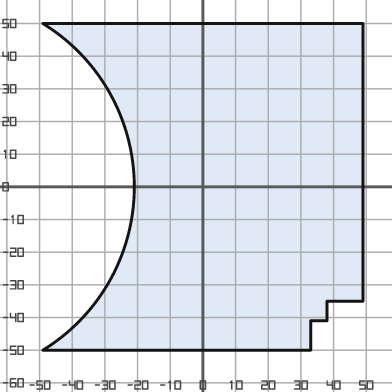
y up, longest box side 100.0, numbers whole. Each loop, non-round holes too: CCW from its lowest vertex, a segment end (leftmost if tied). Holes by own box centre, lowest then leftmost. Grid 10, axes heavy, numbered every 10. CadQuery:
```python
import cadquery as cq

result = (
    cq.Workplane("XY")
    .moveTo(-49.0, -50.0)
    .lineTo(33.0, -50.0)
    .lineTo(33.0, -41.0)
    .lineTo(38.0, -41.0)
    .lineTo(38.0, -35.0)
    .lineTo(49.0, -35.0)
    .lineTo(49.0, 50.0)
    .lineTo(-49.0, 50.0)
    .threePointArc((-21.0, 0.0), (-49.0, -50.0))
    .close()
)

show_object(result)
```